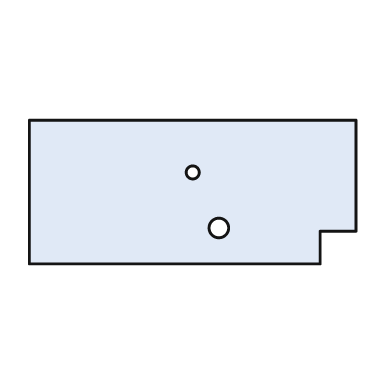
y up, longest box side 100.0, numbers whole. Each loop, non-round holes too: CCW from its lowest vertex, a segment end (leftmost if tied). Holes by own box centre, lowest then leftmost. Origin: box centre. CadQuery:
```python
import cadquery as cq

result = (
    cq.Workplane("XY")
    .moveTo(-50.0, -22.0)
    .lineTo(39.0, -22.0)
    .lineTo(39.0, -12.0)
    .lineTo(50.0, -12.0)
    .lineTo(50.0, 22.0)
    .lineTo(-50.0, 22.0)
    .close()
    .moveTo(8.0, -11.0)
    .circle(3.0)
    .moveTo(0.0, 6.0)
    .circle(2.0)
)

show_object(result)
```